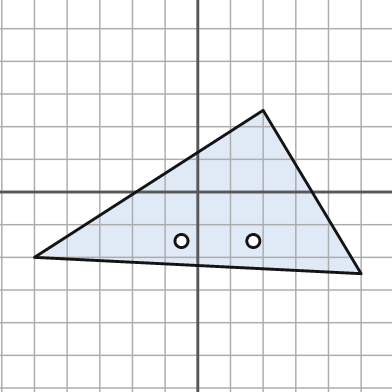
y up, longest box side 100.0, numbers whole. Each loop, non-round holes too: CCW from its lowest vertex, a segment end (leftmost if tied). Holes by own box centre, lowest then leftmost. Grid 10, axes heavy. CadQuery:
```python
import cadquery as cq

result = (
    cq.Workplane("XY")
    .moveTo(50.0, -25.0)
    .lineTo(20.0, 25.0)
    .lineTo(-50.0, -20.0)
    .close()
    .moveTo(-5.0, -15.0)
    .circle(2.0)
    .moveTo(17.0, -15.0)
    .circle(2.0)
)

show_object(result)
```